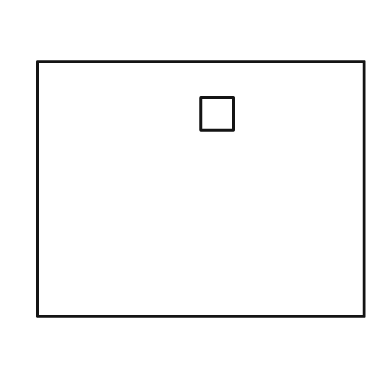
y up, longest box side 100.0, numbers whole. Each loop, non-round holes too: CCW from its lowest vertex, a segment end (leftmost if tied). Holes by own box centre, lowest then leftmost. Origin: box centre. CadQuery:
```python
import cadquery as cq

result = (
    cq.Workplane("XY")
    .moveTo(-50.0, -39.0)
    .lineTo(50.0, -39.0)
    .lineTo(50.0, 39.0)
    .lineTo(-50.0, 39.0)
    .close()
    .moveTo(0.0, 18.0)
    .lineTo(10.0, 18.0)
    .lineTo(10.0, 28.0)
    .lineTo(0.0, 28.0)
    .close()
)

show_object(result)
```